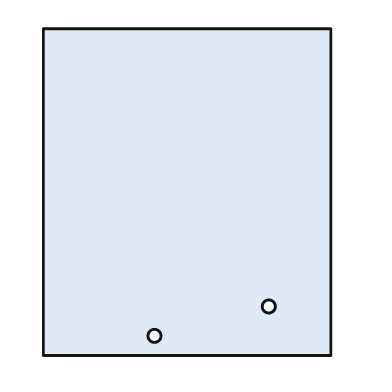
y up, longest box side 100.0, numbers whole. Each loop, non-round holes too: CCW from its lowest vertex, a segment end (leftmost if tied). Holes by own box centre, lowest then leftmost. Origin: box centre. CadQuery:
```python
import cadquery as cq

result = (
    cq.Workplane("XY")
    .moveTo(-44.0, -50.0)
    .lineTo(44.0, -50.0)
    .lineTo(44.0, 50.0)
    .lineTo(-44.0, 50.0)
    .close()
    .moveTo(-10.0, -44.0)
    .circle(2.0)
    .moveTo(25.0, -35.0)
    .circle(2.0)
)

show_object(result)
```